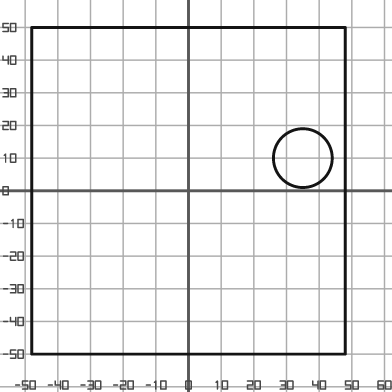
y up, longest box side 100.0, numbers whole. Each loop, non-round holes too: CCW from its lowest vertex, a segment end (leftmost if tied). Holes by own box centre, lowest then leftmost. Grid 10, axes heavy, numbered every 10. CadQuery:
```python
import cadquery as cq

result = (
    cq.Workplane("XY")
    .moveTo(-48.0, -50.0)
    .lineTo(48.0, -50.0)
    .lineTo(48.0, 50.0)
    .lineTo(-48.0, 50.0)
    .close()
    .moveTo(35.0, 10.0)
    .circle(9.0)
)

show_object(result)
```